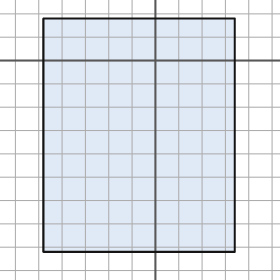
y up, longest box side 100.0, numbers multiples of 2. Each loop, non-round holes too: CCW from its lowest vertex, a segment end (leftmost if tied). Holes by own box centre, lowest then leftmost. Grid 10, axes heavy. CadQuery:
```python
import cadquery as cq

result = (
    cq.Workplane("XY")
    .moveTo(-48.0, -82.0)
    .lineTo(34.0, -82.0)
    .lineTo(34.0, 18.0)
    .lineTo(-48.0, 18.0)
    .close()
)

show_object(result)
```